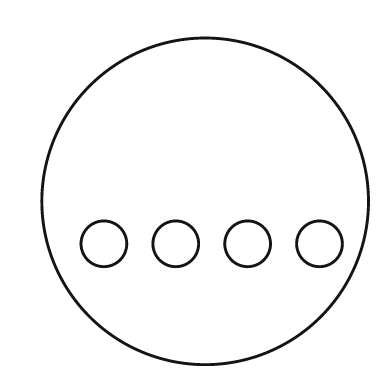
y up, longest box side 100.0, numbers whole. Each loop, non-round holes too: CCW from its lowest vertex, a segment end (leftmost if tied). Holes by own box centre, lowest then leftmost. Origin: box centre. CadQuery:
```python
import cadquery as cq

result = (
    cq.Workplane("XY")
    .moveTo(0.0, 0.0)
    .circle(50.0)
    .moveTo(-31.0, -13.0)
    .circle(7.0)
    .moveTo(-9.0, -13.0)
    .circle(7.0)
    .moveTo(13.0, -13.0)
    .circle(7.0)
    .moveTo(35.0, -13.0)
    .circle(7.0)
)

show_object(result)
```